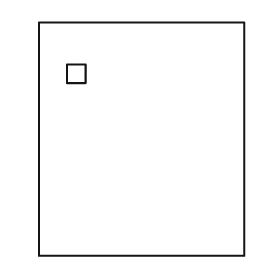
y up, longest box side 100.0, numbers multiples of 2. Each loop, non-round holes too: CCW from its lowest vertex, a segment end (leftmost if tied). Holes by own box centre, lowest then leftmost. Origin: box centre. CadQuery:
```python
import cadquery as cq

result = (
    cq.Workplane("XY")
    .moveTo(-44.0, -50.0)
    .lineTo(44.0, -50.0)
    .lineTo(44.0, 50.0)
    .lineTo(-44.0, 50.0)
    .close()
    .moveTo(-32.0, 24.0)
    .lineTo(-24.0, 24.0)
    .lineTo(-24.0, 32.0)
    .lineTo(-32.0, 32.0)
    .close()
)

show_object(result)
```